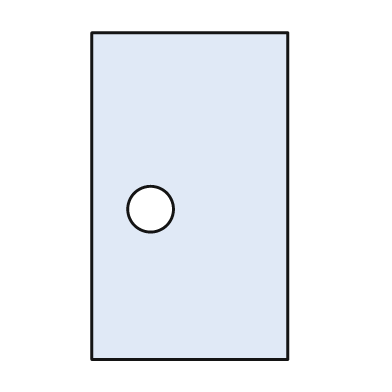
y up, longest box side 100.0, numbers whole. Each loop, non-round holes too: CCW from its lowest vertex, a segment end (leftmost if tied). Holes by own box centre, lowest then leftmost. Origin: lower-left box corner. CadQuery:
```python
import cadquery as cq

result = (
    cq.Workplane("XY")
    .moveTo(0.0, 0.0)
    .lineTo(60.0, 0.0)
    .lineTo(60.0, 100.0)
    .lineTo(0.0, 100.0)
    .close()
    .moveTo(18.0, 46.0)
    .circle(7.0)
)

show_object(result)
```